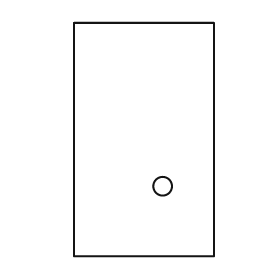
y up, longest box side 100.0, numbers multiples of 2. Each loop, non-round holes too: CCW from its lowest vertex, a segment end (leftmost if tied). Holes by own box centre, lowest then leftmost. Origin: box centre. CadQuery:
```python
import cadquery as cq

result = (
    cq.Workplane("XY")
    .moveTo(-30.0, -50.0)
    .lineTo(30.0, -50.0)
    .lineTo(30.0, 50.0)
    .lineTo(-30.0, 50.0)
    .close()
    .moveTo(8.0, -20.0)
    .circle(4.0)
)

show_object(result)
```